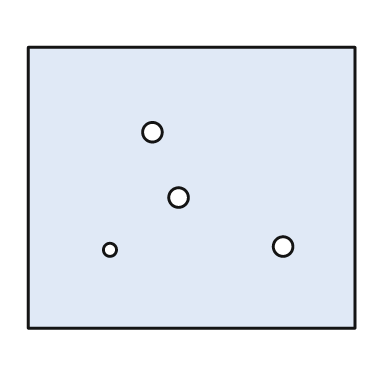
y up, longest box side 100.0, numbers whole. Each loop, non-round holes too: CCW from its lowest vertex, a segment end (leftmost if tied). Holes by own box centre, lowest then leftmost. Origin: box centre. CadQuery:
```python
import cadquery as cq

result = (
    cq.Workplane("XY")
    .moveTo(-50.0, -43.0)
    .lineTo(50.0, -43.0)
    .lineTo(50.0, 43.0)
    .lineTo(-50.0, 43.0)
    .close()
    .moveTo(-25.0, -19.0)
    .circle(2.0)
    .moveTo(28.0, -18.0)
    .circle(3.0)
    .moveTo(-4.0, -3.0)
    .circle(3.0)
    .moveTo(-12.0, 17.0)
    .circle(3.0)
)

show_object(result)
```